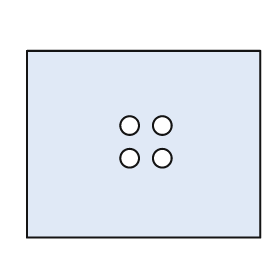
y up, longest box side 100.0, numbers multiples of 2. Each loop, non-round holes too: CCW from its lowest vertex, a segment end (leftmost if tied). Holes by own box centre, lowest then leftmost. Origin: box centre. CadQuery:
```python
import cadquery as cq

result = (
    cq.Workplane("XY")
    .moveTo(-50.0, -40.0)
    .lineTo(50.0, -40.0)
    .lineTo(50.0, 40.0)
    .lineTo(-50.0, 40.0)
    .close()
    .moveTo(-6.0, -6.0)
    .circle(4.0)
    .moveTo(8.0, -6.0)
    .circle(4.0)
    .moveTo(-6.0, 8.0)
    .circle(4.0)
    .moveTo(8.0, 8.0)
    .circle(4.0)
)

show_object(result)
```